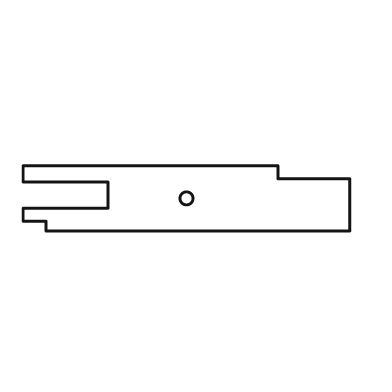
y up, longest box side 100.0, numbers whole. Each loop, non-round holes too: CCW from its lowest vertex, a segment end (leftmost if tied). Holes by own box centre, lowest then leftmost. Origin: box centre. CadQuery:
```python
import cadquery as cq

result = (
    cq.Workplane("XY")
    .moveTo(-43.0, -10.0)
    .lineTo(50.0, -10.0)
    .lineTo(50.0, 6.0)
    .lineTo(28.0, 6.0)
    .lineTo(28.0, 10.0)
    .lineTo(-50.0, 10.0)
    .lineTo(-50.0, 5.0)
    .lineTo(-24.0, 5.0)
    .lineTo(-24.0, -3.0)
    .lineTo(-50.0, -3.0)
    .lineTo(-50.0, -7.0)
    .lineTo(-43.0, -7.0)
    .close()
    .moveTo(0.0, 0.0)
    .circle(2.0)
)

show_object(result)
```